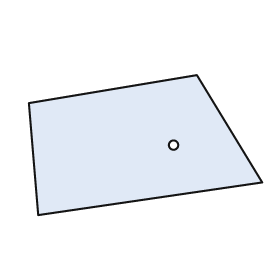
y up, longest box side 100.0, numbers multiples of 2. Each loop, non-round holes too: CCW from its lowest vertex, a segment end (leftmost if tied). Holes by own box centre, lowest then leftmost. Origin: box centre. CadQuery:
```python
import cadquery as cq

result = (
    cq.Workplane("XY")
    .moveTo(-46.0, -30.0)
    .lineTo(50.0, -16.0)
    .lineTo(22.0, 30.0)
    .lineTo(-50.0, 18.0)
    .close()
    .moveTo(12.0, 0.0)
    .circle(2.0)
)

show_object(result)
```